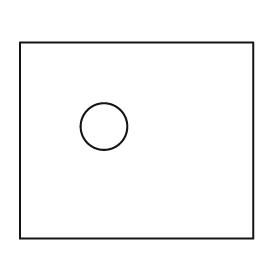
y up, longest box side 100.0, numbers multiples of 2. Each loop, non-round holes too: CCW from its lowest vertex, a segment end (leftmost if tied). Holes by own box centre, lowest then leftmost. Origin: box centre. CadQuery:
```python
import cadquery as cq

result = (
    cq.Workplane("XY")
    .moveTo(-50.0, -42.0)
    .lineTo(50.0, -42.0)
    .lineTo(50.0, 42.0)
    .lineTo(-50.0, 42.0)
    .close()
    .moveTo(-14.0, 6.0)
    .circle(10.0)
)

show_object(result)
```